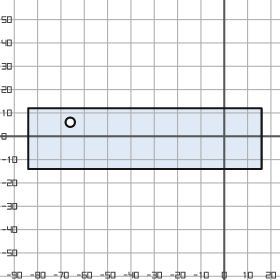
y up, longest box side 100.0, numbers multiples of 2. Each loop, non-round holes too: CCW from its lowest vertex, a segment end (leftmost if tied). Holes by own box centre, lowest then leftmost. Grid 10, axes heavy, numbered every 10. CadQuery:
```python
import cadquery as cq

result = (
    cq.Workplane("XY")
    .moveTo(-84.0, -14.0)
    .lineTo(16.0, -14.0)
    .lineTo(16.0, 12.0)
    .lineTo(-84.0, 12.0)
    .close()
    .moveTo(-66.0, 6.0)
    .circle(2.0)
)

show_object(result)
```